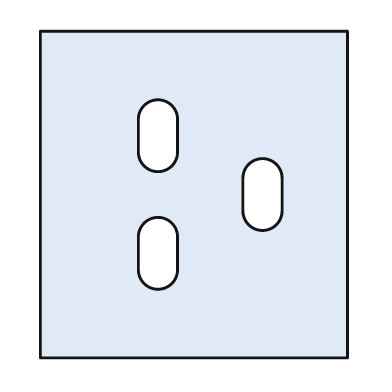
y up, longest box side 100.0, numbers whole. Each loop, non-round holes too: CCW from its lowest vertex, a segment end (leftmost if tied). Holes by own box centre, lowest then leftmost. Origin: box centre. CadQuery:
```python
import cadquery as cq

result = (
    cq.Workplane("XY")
    .moveTo(-47.0, -50.0)
    .lineTo(47.0, -50.0)
    .lineTo(47.0, 50.0)
    .lineTo(-47.0, 50.0)
    .close()
    .moveTo(-17.0, -23.0)
    .threePointArc((-11.0, -29.0), (-5.0, -23.0))
    .lineTo(-5.0, -13.0)
    .threePointArc((-11.0, -7.0), (-17.0, -13.0))
    .close()
    .moveTo(15.0, -5.0)
    .threePointArc((21.0, -11.0), (27.0, -5.0))
    .lineTo(27.0, 5.0)
    .threePointArc((21.0, 11.0), (15.0, 5.0))
    .close()
    .moveTo(-17.0, 13.0)
    .threePointArc((-11.0, 7.0), (-5.0, 13.0))
    .lineTo(-5.0, 23.0)
    .threePointArc((-11.0, 29.0), (-17.0, 23.0))
    .close()
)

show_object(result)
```